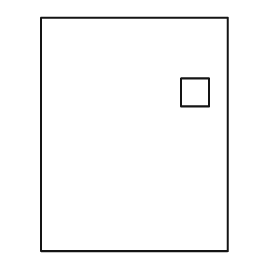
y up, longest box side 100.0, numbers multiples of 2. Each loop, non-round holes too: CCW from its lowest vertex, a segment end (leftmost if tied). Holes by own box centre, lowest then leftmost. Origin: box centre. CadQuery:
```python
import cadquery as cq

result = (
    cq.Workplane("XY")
    .moveTo(-40.0, -50.0)
    .lineTo(40.0, -50.0)
    .lineTo(40.0, 50.0)
    .lineTo(-40.0, 50.0)
    .close()
    .moveTo(20.0, 12.0)
    .lineTo(32.0, 12.0)
    .lineTo(32.0, 24.0)
    .lineTo(20.0, 24.0)
    .close()
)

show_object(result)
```